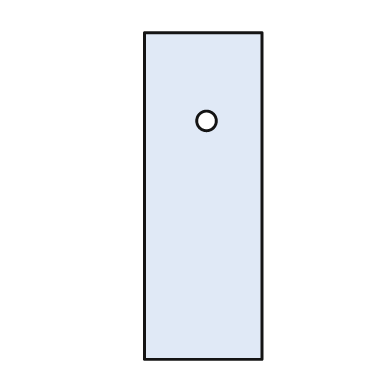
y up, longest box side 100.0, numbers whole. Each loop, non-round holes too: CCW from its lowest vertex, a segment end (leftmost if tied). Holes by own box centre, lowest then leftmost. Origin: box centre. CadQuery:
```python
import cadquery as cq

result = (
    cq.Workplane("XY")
    .moveTo(-18.0, -50.0)
    .lineTo(18.0, -50.0)
    .lineTo(18.0, 50.0)
    .lineTo(-18.0, 50.0)
    .close()
    .moveTo(1.0, 23.0)
    .circle(3.0)
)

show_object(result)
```